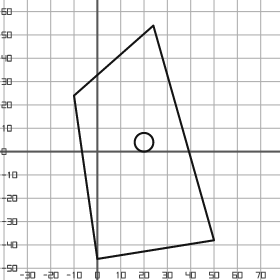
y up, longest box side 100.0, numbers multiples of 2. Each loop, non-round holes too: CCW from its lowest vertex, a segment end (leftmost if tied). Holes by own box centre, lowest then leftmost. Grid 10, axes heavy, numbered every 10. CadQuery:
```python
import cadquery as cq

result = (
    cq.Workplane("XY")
    .moveTo(0.0, -46.0)
    .lineTo(50.0, -38.0)
    .lineTo(24.0, 54.0)
    .lineTo(-10.0, 24.0)
    .close()
    .moveTo(20.0, 4.0)
    .circle(4.0)
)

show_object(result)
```